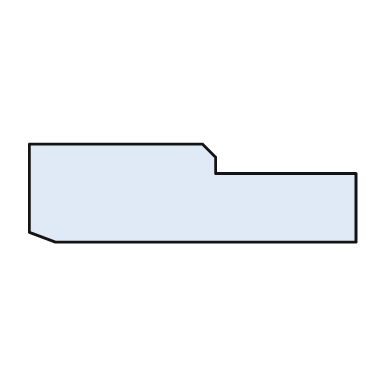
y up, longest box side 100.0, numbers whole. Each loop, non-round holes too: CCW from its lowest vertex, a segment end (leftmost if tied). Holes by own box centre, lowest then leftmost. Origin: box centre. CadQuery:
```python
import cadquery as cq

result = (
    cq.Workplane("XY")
    .moveTo(-42.0, -15.0)
    .lineTo(50.0, -15.0)
    .lineTo(50.0, 6.0)
    .lineTo(7.0, 6.0)
    .lineTo(7.0, 11.0)
    .lineTo(3.0, 15.0)
    .lineTo(-50.0, 15.0)
    .lineTo(-50.0, -12.0)
    .close()
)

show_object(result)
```